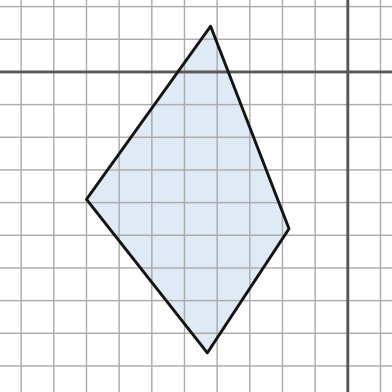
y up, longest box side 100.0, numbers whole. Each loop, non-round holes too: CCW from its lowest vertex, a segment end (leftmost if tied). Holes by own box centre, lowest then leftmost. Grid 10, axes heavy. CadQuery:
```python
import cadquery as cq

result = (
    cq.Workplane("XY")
    .moveTo(-43.0, -86.0)
    .lineTo(-18.0, -48.0)
    .lineTo(-42.0, 14.0)
    .lineTo(-80.0, -39.0)
    .close()
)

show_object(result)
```